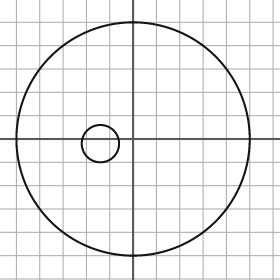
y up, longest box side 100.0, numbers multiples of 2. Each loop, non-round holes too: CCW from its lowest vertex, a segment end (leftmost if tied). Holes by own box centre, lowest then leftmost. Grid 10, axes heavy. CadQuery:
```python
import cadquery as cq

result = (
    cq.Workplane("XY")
    .moveTo(0.0, 0.0)
    .circle(50.0)
    .moveTo(-14.0, -2.0)
    .circle(8.0)
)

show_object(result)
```